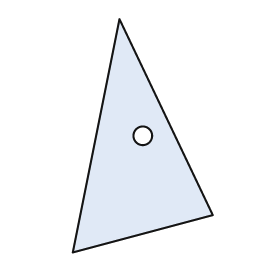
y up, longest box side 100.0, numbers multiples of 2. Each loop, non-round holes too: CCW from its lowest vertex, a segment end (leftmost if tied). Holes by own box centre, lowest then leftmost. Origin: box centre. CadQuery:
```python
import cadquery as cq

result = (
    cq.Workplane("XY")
    .moveTo(-30.0, -50.0)
    .lineTo(30.0, -34.0)
    .lineTo(-10.0, 50.0)
    .close()
    .moveTo(0.0, 0.0)
    .circle(4.0)
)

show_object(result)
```